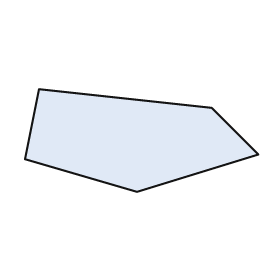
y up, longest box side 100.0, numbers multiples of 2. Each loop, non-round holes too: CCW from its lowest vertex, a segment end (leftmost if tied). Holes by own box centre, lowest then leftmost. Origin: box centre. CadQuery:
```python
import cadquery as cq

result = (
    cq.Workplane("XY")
    .moveTo(-2.0, -22.0)
    .lineTo(50.0, -6.0)
    .lineTo(30.0, 14.0)
    .lineTo(-44.0, 22.0)
    .lineTo(-50.0, -8.0)
    .close()
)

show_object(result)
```